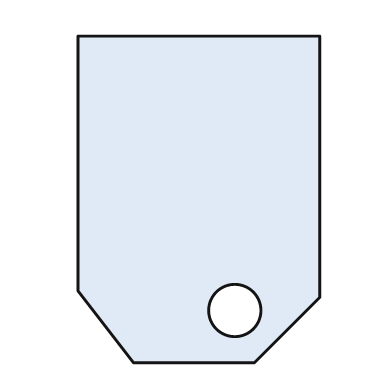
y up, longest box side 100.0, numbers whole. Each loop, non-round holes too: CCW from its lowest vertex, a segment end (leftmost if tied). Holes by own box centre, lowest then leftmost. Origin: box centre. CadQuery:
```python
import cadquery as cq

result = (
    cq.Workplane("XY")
    .moveTo(-20.0, -50.0)
    .lineTo(17.0, -50.0)
    .lineTo(37.0, -30.0)
    .lineTo(37.0, 50.0)
    .lineTo(-37.0, 50.0)
    .lineTo(-37.0, -28.0)
    .close()
    .moveTo(11.0, -34.0)
    .circle(8.0)
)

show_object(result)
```